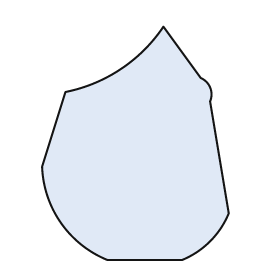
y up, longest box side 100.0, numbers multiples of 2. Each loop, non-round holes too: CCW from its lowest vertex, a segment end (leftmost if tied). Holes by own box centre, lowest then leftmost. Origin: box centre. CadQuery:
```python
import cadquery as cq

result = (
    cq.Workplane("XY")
    .moveTo(-12.0, -50.0)
    .lineTo(20.0, -50.0)
    .threePointArc((32.0, -42.0), (40.0, -30.0))
    .lineTo(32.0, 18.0)
    .threePointArc((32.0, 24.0), (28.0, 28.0))
    .lineTo(12.0, 50.0)
    .threePointArc((-6.0, 32.0), (-30.0, 22.0))
    .lineTo(-40.0, -10.0)
    .threePointArc((-32.0, -34.0), (-12.0, -50.0))
    .close()
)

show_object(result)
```